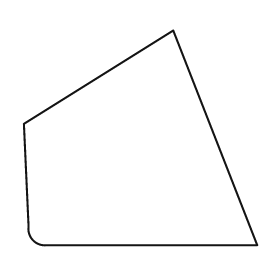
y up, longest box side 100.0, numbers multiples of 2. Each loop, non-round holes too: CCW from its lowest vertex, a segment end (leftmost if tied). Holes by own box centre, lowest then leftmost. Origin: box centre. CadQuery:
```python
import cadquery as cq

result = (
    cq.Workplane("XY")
    .moveTo(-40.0, -46.0)
    .lineTo(50.0, -46.0)
    .lineTo(14.0, 46.0)
    .lineTo(-50.0, 6.0)
    .lineTo(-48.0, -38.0)
    .threePointArc((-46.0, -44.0), (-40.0, -46.0))
    .close()
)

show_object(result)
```